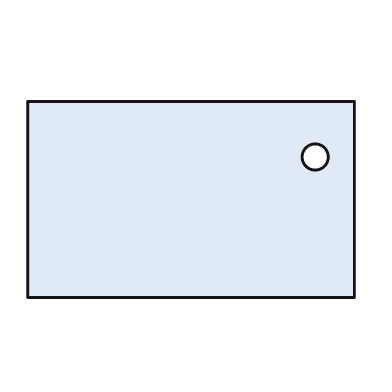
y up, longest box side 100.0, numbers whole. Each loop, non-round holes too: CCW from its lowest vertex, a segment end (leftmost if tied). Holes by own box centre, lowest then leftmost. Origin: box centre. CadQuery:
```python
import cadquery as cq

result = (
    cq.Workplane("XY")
    .moveTo(-50.0, -30.0)
    .lineTo(50.0, -30.0)
    .lineTo(50.0, 30.0)
    .lineTo(-50.0, 30.0)
    .close()
    .moveTo(38.0, 13.0)
    .circle(4.0)
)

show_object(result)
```